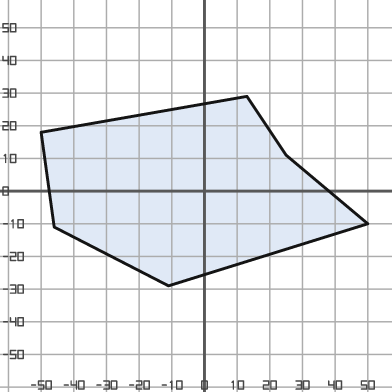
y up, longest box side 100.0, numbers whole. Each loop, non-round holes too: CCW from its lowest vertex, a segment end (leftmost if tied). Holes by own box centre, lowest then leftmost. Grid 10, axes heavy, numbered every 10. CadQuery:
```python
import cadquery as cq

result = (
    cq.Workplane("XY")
    .moveTo(-11.0, -29.0)
    .lineTo(50.0, -10.0)
    .lineTo(25.0, 11.0)
    .lineTo(13.0, 29.0)
    .lineTo(-50.0, 18.0)
    .lineTo(-46.0, -11.0)
    .close()
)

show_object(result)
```